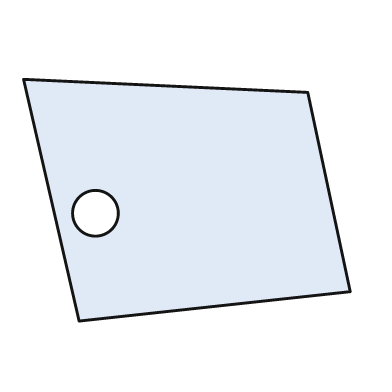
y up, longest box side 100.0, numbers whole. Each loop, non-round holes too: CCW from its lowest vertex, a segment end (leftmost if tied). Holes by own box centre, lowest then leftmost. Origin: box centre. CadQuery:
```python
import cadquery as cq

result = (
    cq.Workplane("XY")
    .moveTo(-33.0, -37.0)
    .lineTo(50.0, -28.0)
    .lineTo(37.0, 33.0)
    .lineTo(-50.0, 37.0)
    .close()
    .moveTo(-28.0, -4.0)
    .circle(7.0)
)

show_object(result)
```